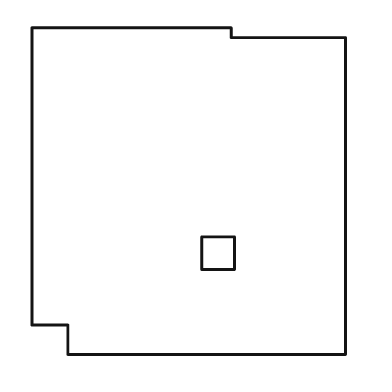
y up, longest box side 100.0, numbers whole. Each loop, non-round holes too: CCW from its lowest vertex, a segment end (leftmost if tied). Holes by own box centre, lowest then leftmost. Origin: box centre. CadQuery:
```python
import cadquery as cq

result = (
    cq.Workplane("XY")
    .moveTo(-37.0, -50.0)
    .lineTo(48.0, -50.0)
    .lineTo(48.0, 47.0)
    .lineTo(13.0, 47.0)
    .lineTo(13.0, 50.0)
    .lineTo(-48.0, 50.0)
    .lineTo(-48.0, -41.0)
    .lineTo(-37.0, -41.0)
    .close()
    .moveTo(4.0, -24.0)
    .lineTo(14.0, -24.0)
    .lineTo(14.0, -14.0)
    .lineTo(4.0, -14.0)
    .close()
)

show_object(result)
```